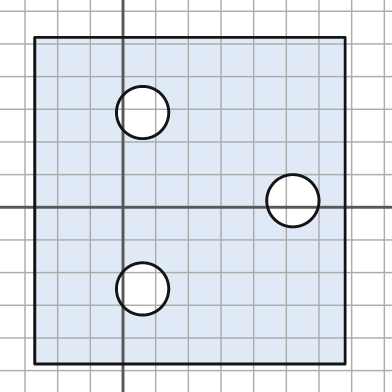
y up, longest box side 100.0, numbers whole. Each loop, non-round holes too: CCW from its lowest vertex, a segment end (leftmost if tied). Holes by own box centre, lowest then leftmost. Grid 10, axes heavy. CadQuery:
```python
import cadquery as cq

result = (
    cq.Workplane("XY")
    .moveTo(-27.0, -48.0)
    .lineTo(68.0, -48.0)
    .lineTo(68.0, 52.0)
    .lineTo(-27.0, 52.0)
    .close()
    .moveTo(6.0, -25.0)
    .circle(8.0)
    .moveTo(52.0, 2.0)
    .circle(8.0)
    .moveTo(6.0, 29.0)
    .circle(8.0)
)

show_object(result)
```